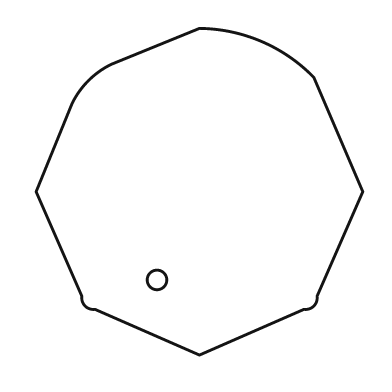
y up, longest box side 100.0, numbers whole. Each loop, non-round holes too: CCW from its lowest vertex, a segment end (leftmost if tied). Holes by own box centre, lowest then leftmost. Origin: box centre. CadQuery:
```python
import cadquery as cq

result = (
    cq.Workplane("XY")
    .moveTo(0.0, -50.0)
    .lineTo(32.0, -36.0)
    .threePointArc((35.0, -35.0), (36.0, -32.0))
    .lineTo(50.0, 0.0)
    .lineTo(35.0, 35.0)
    .threePointArc((19.0, 46.0), (0.0, 50.0))
    .lineTo(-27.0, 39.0)
    .threePointArc((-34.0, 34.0), (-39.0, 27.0))
    .lineTo(-50.0, 0.0)
    .lineTo(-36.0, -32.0)
    .threePointArc((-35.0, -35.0), (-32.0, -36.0))
    .close()
    .moveTo(-13.0, -27.0)
    .circle(3.0)
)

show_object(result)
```